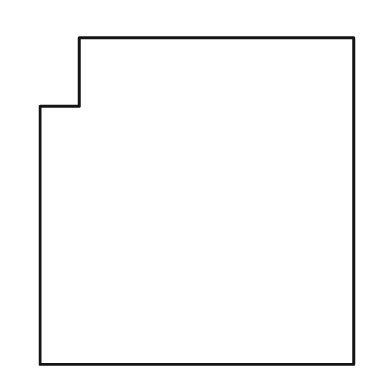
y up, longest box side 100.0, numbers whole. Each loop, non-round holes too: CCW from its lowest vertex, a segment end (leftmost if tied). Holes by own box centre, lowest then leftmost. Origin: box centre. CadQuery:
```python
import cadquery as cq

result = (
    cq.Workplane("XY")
    .moveTo(-48.0, -50.0)
    .lineTo(48.0, -50.0)
    .lineTo(48.0, 50.0)
    .lineTo(-36.0, 50.0)
    .lineTo(-36.0, 29.0)
    .lineTo(-48.0, 29.0)
    .close()
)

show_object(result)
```